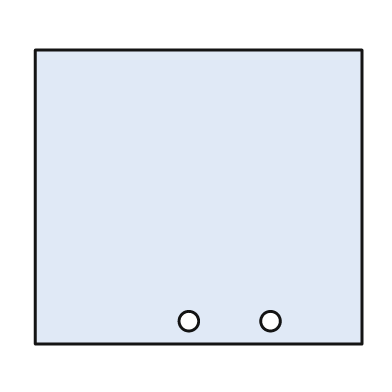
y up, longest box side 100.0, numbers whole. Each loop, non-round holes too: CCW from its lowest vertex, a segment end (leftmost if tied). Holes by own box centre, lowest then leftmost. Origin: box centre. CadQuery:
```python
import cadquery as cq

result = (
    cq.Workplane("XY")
    .moveTo(-50.0, -45.0)
    .lineTo(50.0, -45.0)
    .lineTo(50.0, 45.0)
    .lineTo(-50.0, 45.0)
    .close()
    .moveTo(-3.0, -38.0)
    .circle(3.0)
    .moveTo(22.0, -38.0)
    .circle(3.0)
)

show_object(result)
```